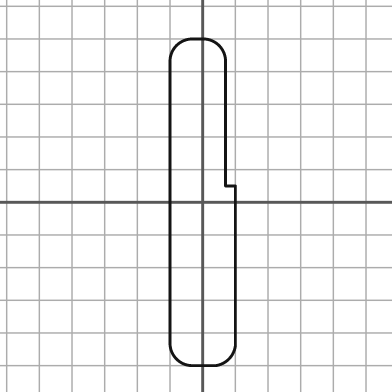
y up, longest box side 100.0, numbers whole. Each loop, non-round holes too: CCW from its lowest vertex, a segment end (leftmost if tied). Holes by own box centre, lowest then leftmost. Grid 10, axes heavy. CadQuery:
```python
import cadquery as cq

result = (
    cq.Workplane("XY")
    .moveTo(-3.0, -50.0)
    .lineTo(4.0, -50.0)
    .threePointArc((8.0, -48.0), (10.0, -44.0))
    .lineTo(10.0, 5.0)
    .lineTo(7.0, 5.0)
    .lineTo(7.0, 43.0)
    .threePointArc((5.0, 48.0), (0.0, 50.0))
    .lineTo(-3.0, 50.0)
    .threePointArc((-8.0, 48.0), (-10.0, 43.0))
    .lineTo(-10.0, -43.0)
    .threePointArc((-8.0, -48.0), (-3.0, -50.0))
    .close()
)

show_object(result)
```